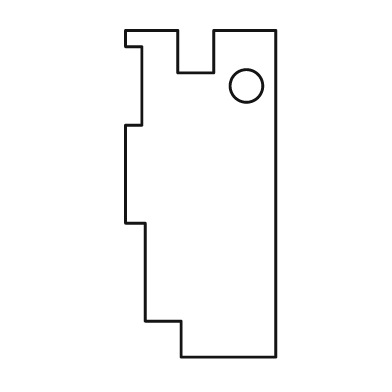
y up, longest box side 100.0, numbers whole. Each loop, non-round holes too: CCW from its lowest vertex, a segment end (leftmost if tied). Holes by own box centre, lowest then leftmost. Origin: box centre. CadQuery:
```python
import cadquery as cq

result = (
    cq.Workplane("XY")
    .moveTo(-6.0, -50.0)
    .lineTo(23.0, -50.0)
    .lineTo(23.0, 50.0)
    .lineTo(4.0, 50.0)
    .lineTo(4.0, 37.0)
    .lineTo(-7.0, 37.0)
    .lineTo(-7.0, 50.0)
    .lineTo(-23.0, 50.0)
    .lineTo(-23.0, 45.0)
    .lineTo(-18.0, 45.0)
    .lineTo(-18.0, 21.0)
    .lineTo(-23.0, 21.0)
    .lineTo(-23.0, -9.0)
    .lineTo(-17.0, -9.0)
    .lineTo(-17.0, -39.0)
    .lineTo(-6.0, -39.0)
    .close()
    .moveTo(14.0, 33.0)
    .circle(5.0)
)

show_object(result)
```